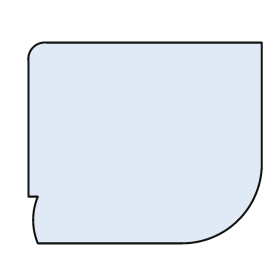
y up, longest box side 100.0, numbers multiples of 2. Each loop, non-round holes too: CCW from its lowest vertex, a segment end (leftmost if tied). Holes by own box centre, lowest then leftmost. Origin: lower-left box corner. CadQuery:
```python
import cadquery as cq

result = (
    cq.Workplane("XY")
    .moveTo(4.0, 0.0)
    .lineTo(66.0, 0.0)
    .threePointArc((90.0, 10.0), (100.0, 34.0))
    .lineTo(100.0, 86.0)
    .lineTo(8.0, 86.0)
    .threePointArc((2.0, 84.0), (0.0, 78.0))
    .lineTo(0.0, 20.0)
    .lineTo(4.0, 20.0)
    .threePointArc((2.0, 10.0), (4.0, 0.0))
    .close()
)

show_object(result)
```